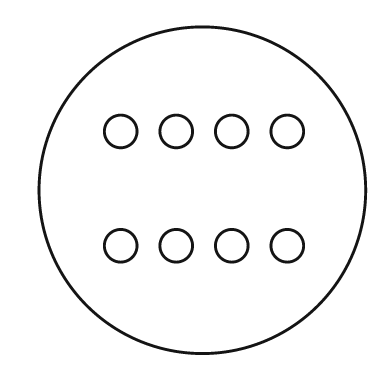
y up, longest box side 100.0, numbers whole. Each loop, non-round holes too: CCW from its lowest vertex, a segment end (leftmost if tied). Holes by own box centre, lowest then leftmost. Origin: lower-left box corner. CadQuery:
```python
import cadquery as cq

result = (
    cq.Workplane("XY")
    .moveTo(50.0, 50.0)
    .circle(50.0)
    .moveTo(25.0, 33.0)
    .circle(5.0)
    .moveTo(42.0, 33.0)
    .circle(5.0)
    .moveTo(59.0, 33.0)
    .circle(5.0)
    .moveTo(76.0, 33.0)
    .circle(5.0)
    .moveTo(25.0, 68.0)
    .circle(5.0)
    .moveTo(42.0, 68.0)
    .circle(5.0)
    .moveTo(59.0, 68.0)
    .circle(5.0)
    .moveTo(76.0, 68.0)
    .circle(5.0)
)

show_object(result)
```